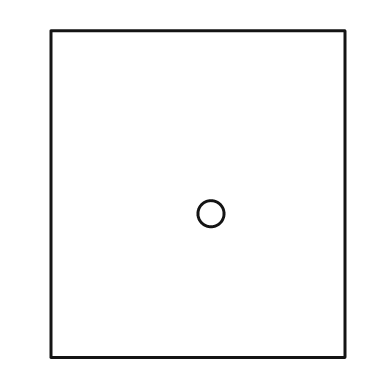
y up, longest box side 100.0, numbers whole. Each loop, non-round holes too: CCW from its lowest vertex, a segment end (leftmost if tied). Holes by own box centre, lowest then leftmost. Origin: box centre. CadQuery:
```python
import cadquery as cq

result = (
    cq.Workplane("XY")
    .moveTo(-45.0, -50.0)
    .lineTo(45.0, -50.0)
    .lineTo(45.0, 50.0)
    .lineTo(-45.0, 50.0)
    .close()
    .moveTo(4.0, -6.0)
    .circle(4.0)
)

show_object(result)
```